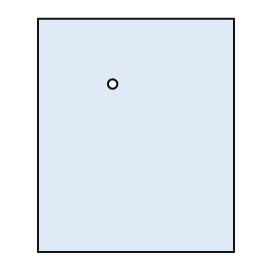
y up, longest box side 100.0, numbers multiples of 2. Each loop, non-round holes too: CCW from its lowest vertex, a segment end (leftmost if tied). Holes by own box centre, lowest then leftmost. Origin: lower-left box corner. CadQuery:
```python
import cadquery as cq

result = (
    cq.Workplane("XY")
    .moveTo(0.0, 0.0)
    .lineTo(84.0, 0.0)
    .lineTo(84.0, 100.0)
    .lineTo(0.0, 100.0)
    .close()
    .moveTo(32.0, 72.0)
    .circle(2.0)
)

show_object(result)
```